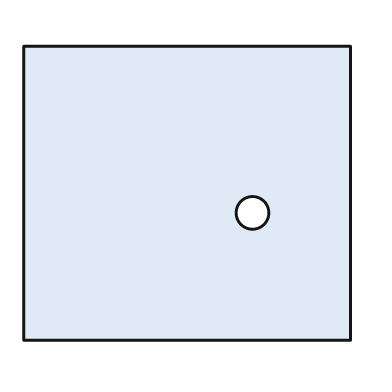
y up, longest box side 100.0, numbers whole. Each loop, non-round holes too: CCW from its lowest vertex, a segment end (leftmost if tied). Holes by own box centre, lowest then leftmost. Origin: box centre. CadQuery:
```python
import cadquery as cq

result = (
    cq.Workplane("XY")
    .moveTo(-50.0, -45.0)
    .lineTo(50.0, -45.0)
    .lineTo(50.0, 45.0)
    .lineTo(-50.0, 45.0)
    .close()
    .moveTo(20.0, -6.0)
    .circle(5.0)
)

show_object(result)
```